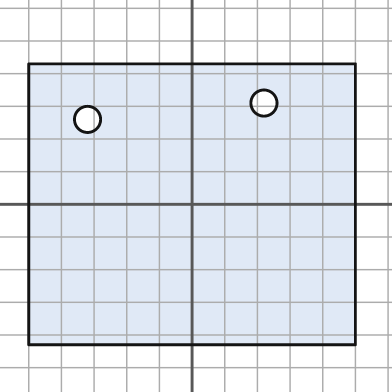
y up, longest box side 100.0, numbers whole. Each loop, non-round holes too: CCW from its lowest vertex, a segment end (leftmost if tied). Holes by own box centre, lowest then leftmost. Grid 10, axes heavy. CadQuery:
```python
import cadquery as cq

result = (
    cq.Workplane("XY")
    .moveTo(-50.0, -43.0)
    .lineTo(50.0, -43.0)
    .lineTo(50.0, 43.0)
    .lineTo(-50.0, 43.0)
    .close()
    .moveTo(-32.0, 26.0)
    .circle(4.0)
    .moveTo(22.0, 31.0)
    .circle(4.0)
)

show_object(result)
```